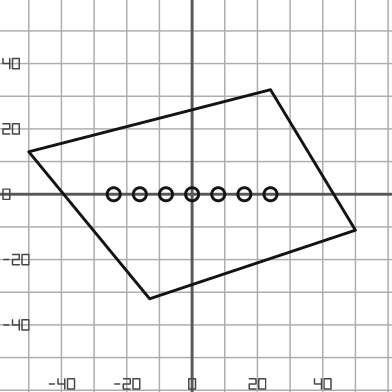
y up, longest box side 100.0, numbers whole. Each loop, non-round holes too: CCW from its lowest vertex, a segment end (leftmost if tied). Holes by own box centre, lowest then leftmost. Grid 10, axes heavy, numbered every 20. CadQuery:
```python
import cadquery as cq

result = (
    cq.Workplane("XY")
    .moveTo(-13.0, -32.0)
    .lineTo(50.0, -11.0)
    .lineTo(24.0, 32.0)
    .lineTo(-50.0, 13.0)
    .close()
    .moveTo(-24.0, 0.0)
    .circle(2.0)
    .moveTo(-16.0, 0.0)
    .circle(2.0)
    .moveTo(-8.0, 0.0)
    .circle(2.0)
    .moveTo(0.0, 0.0)
    .circle(2.0)
    .moveTo(8.0, 0.0)
    .circle(2.0)
    .moveTo(16.0, 0.0)
    .circle(2.0)
    .moveTo(24.0, 0.0)
    .circle(2.0)
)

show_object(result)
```